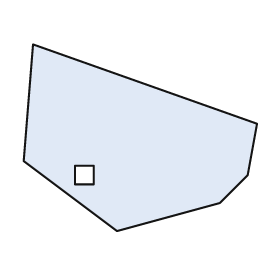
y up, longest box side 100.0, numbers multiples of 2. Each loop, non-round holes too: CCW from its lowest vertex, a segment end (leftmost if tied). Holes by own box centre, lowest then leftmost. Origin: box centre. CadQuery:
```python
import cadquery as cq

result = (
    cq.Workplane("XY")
    .moveTo(-10.0, -40.0)
    .lineTo(34.0, -28.0)
    .lineTo(46.0, -16.0)
    .lineTo(50.0, 6.0)
    .lineTo(-46.0, 40.0)
    .lineTo(-50.0, -10.0)
    .close()
    .moveTo(-28.0, -20.0)
    .lineTo(-20.0, -20.0)
    .lineTo(-20.0, -12.0)
    .lineTo(-28.0, -12.0)
    .close()
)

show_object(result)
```